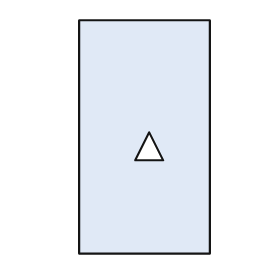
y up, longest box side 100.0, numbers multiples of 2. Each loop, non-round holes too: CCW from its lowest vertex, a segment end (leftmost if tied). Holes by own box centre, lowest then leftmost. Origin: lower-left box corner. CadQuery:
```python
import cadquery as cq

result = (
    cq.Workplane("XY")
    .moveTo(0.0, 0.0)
    .lineTo(56.0, 0.0)
    .lineTo(56.0, 100.0)
    .lineTo(0.0, 100.0)
    .close()
    .moveTo(24.0, 40.0)
    .lineTo(36.0, 40.0)
    .lineTo(30.0, 52.0)
    .close()
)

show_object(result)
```